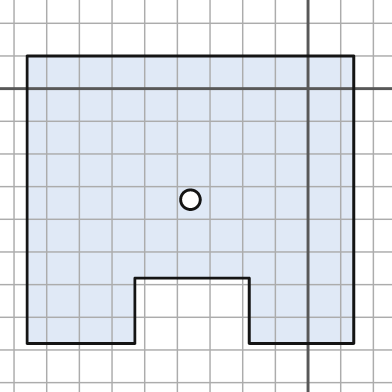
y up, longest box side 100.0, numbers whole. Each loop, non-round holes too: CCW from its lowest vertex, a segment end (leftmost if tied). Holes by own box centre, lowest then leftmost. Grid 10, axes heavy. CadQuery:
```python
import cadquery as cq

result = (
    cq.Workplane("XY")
    .moveTo(-86.0, -78.0)
    .lineTo(-53.0, -78.0)
    .lineTo(-53.0, -58.0)
    .lineTo(-18.0, -58.0)
    .lineTo(-18.0, -78.0)
    .lineTo(14.0, -78.0)
    .lineTo(14.0, 10.0)
    .lineTo(-86.0, 10.0)
    .close()
    .moveTo(-36.0, -34.0)
    .circle(3.0)
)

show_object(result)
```